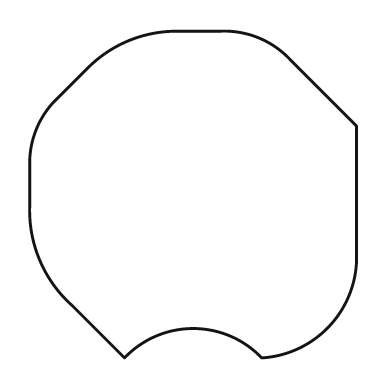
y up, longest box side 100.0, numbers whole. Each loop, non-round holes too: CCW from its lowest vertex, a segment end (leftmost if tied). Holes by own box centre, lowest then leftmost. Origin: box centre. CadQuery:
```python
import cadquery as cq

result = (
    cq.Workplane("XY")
    .moveTo(-21.0, -50.0)
    .threePointArc((0.0, -41.0), (21.0, -50.0))
    .threePointArc((41.0, -41.0), (50.0, -21.0))
    .lineTo(50.0, 21.0)
    .lineTo(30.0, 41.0)
    .threePointArc((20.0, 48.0), (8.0, 50.0))
    .lineTo(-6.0, 50.0)
    .threePointArc((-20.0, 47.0), (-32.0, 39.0))
    .lineTo(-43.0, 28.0)
    .threePointArc((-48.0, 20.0), (-50.0, 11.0))
    .lineTo(-50.0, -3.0)
    .threePointArc((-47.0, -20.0), (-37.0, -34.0))
    .close()
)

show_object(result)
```